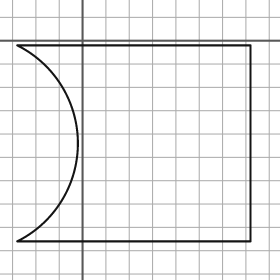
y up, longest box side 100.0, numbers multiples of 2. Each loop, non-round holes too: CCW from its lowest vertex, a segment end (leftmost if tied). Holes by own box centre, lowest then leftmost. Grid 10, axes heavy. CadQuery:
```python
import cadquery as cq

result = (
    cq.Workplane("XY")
    .moveTo(-28.0, -86.0)
    .lineTo(72.0, -86.0)
    .lineTo(72.0, -2.0)
    .lineTo(-28.0, -2.0)
    .threePointArc((-2.0, -44.0), (-28.0, -86.0))
    .close()
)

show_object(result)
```